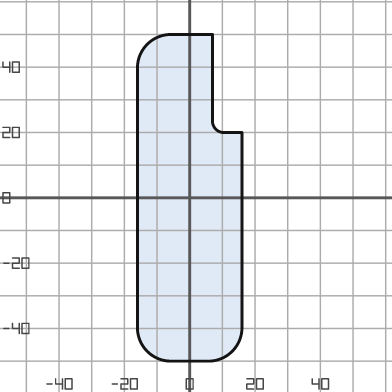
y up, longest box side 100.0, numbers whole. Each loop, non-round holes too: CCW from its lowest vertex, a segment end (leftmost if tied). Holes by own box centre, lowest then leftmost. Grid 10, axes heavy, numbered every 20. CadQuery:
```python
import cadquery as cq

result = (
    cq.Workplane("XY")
    .moveTo(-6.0, -50.0)
    .lineTo(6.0, -50.0)
    .threePointArc((13.0, -47.0), (16.0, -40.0))
    .lineTo(16.0, 20.0)
    .lineTo(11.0, 20.0)
    .threePointArc((8.0, 21.0), (7.0, 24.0))
    .lineTo(7.0, 50.0)
    .lineTo(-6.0, 50.0)
    .threePointArc((-13.0, 47.0), (-16.0, 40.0))
    .lineTo(-16.0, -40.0)
    .threePointArc((-13.0, -47.0), (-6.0, -50.0))
    .close()
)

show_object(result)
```